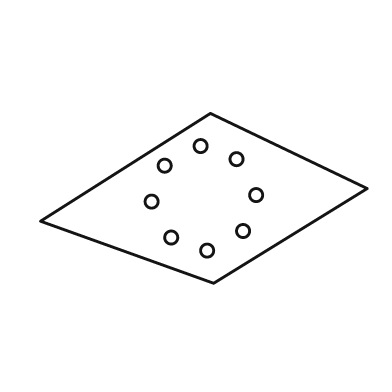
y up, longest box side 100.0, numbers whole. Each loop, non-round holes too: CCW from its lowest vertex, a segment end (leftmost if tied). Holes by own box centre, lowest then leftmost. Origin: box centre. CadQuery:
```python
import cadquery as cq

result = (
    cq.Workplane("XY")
    .moveTo(3.0, -26.0)
    .lineTo(50.0, 3.0)
    .lineTo(2.0, 26.0)
    .lineTo(-50.0, -7.0)
    .close()
    .moveTo(1.0, -16.0)
    .circle(2.0)
    .moveTo(-10.0, -12.0)
    .circle(2.0)
    .moveTo(12.0, -10.0)
    .circle(2.0)
    .moveTo(-16.0, -1.0)
    .circle(2.0)
    .moveTo(16.0, 1.0)
    .circle(2.0)
    .moveTo(-12.0, 10.0)
    .circle(2.0)
    .moveTo(10.0, 12.0)
    .circle(2.0)
    .moveTo(-1.0, 16.0)
    .circle(2.0)
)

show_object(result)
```